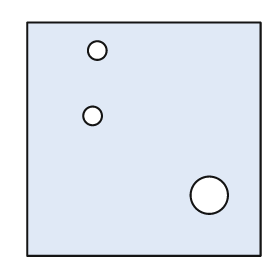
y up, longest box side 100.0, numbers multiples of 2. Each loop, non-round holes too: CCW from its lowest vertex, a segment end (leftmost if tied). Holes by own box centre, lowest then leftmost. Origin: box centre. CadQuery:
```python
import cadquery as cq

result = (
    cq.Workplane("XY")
    .moveTo(-50.0, -50.0)
    .lineTo(50.0, -50.0)
    .lineTo(50.0, 50.0)
    .lineTo(-50.0, 50.0)
    .close()
    .moveTo(28.0, -24.0)
    .circle(8.0)
    .moveTo(-22.0, 10.0)
    .circle(4.0)
    .moveTo(-20.0, 38.0)
    .circle(4.0)
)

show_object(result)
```